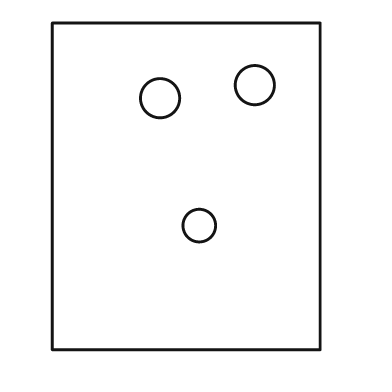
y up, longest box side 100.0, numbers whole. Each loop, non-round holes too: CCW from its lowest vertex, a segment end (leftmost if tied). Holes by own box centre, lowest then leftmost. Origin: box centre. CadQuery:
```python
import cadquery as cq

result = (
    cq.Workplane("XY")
    .moveTo(-41.0, -50.0)
    .lineTo(41.0, -50.0)
    .lineTo(41.0, 50.0)
    .lineTo(-41.0, 50.0)
    .close()
    .moveTo(4.0, -12.0)
    .circle(5.0)
    .moveTo(-8.0, 27.0)
    .circle(6.0)
    .moveTo(21.0, 31.0)
    .circle(6.0)
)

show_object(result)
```